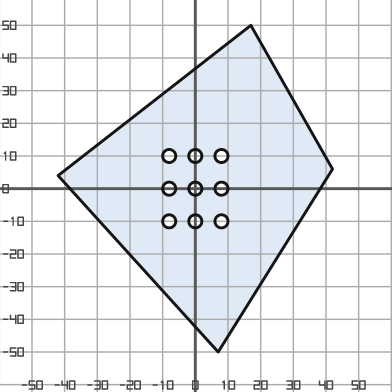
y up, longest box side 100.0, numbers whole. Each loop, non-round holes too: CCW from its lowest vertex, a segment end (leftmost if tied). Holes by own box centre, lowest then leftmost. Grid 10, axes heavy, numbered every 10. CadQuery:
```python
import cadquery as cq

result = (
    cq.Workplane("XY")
    .moveTo(7.0, -50.0)
    .lineTo(42.0, 6.0)
    .lineTo(17.0, 50.0)
    .lineTo(-42.0, 4.0)
    .close()
    .moveTo(-8.0, -10.0)
    .circle(2.0)
    .moveTo(0.0, -10.0)
    .circle(2.0)
    .moveTo(8.0, -10.0)
    .circle(2.0)
    .moveTo(-8.0, 0.0)
    .circle(2.0)
    .moveTo(0.0, 0.0)
    .circle(2.0)
    .moveTo(8.0, 0.0)
    .circle(2.0)
    .moveTo(-8.0, 10.0)
    .circle(2.0)
    .moveTo(0.0, 10.0)
    .circle(2.0)
    .moveTo(8.0, 10.0)
    .circle(2.0)
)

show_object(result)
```